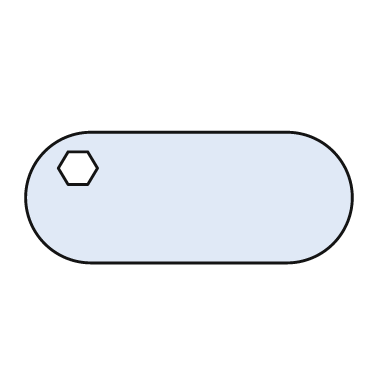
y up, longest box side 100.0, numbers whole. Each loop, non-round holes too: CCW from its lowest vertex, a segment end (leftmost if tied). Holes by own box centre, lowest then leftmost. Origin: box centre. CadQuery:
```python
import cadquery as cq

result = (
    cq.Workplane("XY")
    .moveTo(-30.0, -20.0)
    .lineTo(30.0, -20.0)
    .threePointArc((50.0, 0.0), (30.0, 20.0))
    .lineTo(-30.0, 20.0)
    .threePointArc((-50.0, 0.0), (-30.0, -20.0))
    .close()
    .moveTo(-37.0, 4.0)
    .lineTo(-31.0, 4.0)
    .lineTo(-28.0, 9.0)
    .lineTo(-31.0, 14.0)
    .lineTo(-37.0, 14.0)
    .lineTo(-40.0, 9.0)
    .close()
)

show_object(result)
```